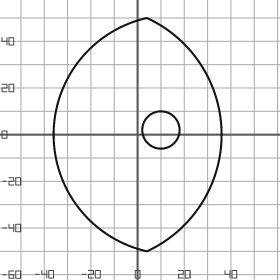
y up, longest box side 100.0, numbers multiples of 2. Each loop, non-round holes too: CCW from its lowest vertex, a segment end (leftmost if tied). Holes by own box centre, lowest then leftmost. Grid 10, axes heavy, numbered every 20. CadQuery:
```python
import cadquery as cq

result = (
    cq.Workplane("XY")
    .moveTo(4.0, -50.0)
    .threePointArc((36.0, 0.0), (4.0, 50.0))
    .threePointArc((-36.0, 0.0), (4.0, -50.0))
    .close()
    .moveTo(10.0, 2.0)
    .circle(8.0)
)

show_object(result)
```